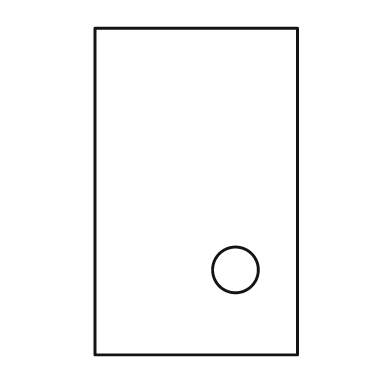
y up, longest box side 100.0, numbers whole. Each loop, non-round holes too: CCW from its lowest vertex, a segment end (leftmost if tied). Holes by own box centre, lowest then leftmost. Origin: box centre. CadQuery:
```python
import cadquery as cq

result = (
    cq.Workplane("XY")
    .moveTo(-31.0, -50.0)
    .lineTo(31.0, -50.0)
    .lineTo(31.0, 50.0)
    .lineTo(-31.0, 50.0)
    .close()
    .moveTo(12.0, -24.0)
    .circle(7.0)
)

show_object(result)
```